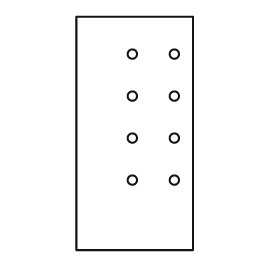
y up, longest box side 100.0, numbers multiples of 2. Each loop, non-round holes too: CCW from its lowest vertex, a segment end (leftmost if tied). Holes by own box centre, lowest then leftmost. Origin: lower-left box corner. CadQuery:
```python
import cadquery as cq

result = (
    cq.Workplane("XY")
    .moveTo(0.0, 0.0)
    .lineTo(50.0, 0.0)
    .lineTo(50.0, 100.0)
    .lineTo(0.0, 100.0)
    .close()
    .moveTo(24.0, 30.0)
    .circle(2.0)
    .moveTo(42.0, 30.0)
    .circle(2.0)
    .moveTo(24.0, 48.0)
    .circle(2.0)
    .moveTo(42.0, 48.0)
    .circle(2.0)
    .moveTo(24.0, 66.0)
    .circle(2.0)
    .moveTo(42.0, 66.0)
    .circle(2.0)
    .moveTo(24.0, 84.0)
    .circle(2.0)
    .moveTo(42.0, 84.0)
    .circle(2.0)
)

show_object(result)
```